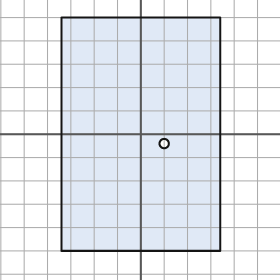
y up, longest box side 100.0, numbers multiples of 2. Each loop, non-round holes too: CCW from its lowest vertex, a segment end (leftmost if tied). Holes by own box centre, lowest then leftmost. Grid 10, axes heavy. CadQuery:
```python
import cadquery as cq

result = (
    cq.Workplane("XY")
    .moveTo(-34.0, -50.0)
    .lineTo(34.0, -50.0)
    .lineTo(34.0, 50.0)
    .lineTo(-34.0, 50.0)
    .close()
    .moveTo(10.0, -4.0)
    .circle(2.0)
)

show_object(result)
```